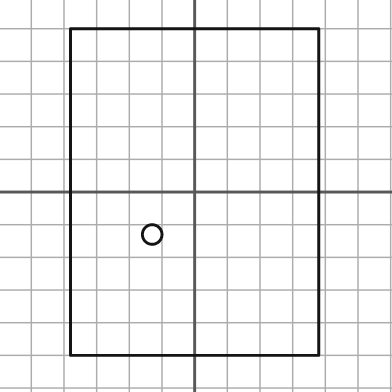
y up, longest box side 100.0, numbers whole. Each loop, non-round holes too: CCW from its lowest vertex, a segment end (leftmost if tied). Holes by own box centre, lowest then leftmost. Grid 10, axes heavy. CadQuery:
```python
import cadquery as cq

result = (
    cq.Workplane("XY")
    .moveTo(-38.0, -50.0)
    .lineTo(38.0, -50.0)
    .lineTo(38.0, 50.0)
    .lineTo(-38.0, 50.0)
    .close()
    .moveTo(-13.0, -13.0)
    .circle(3.0)
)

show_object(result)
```